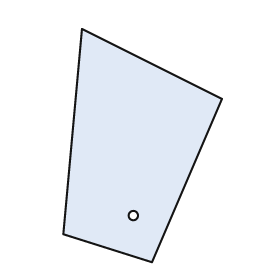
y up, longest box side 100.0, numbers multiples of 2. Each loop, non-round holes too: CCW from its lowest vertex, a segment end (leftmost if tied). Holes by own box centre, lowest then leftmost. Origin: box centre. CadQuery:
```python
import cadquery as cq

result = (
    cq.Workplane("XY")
    .moveTo(4.0, -50.0)
    .lineTo(34.0, 20.0)
    .lineTo(-26.0, 50.0)
    .lineTo(-34.0, -38.0)
    .close()
    .moveTo(-4.0, -30.0)
    .circle(2.0)
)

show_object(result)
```